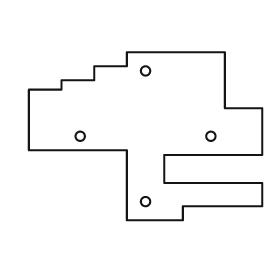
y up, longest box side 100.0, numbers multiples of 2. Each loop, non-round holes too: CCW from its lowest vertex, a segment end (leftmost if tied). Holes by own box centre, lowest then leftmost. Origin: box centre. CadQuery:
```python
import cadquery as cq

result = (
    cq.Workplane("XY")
    .moveTo(-8.0, -36.0)
    .lineTo(16.0, -36.0)
    .lineTo(16.0, -30.0)
    .lineTo(50.0, -30.0)
    .lineTo(50.0, -20.0)
    .lineTo(8.0, -20.0)
    .lineTo(8.0, -8.0)
    .lineTo(50.0, -8.0)
    .lineTo(50.0, 12.0)
    .lineTo(34.0, 12.0)
    .lineTo(34.0, 36.0)
    .lineTo(-8.0, 36.0)
    .lineTo(-8.0, 30.0)
    .lineTo(-22.0, 30.0)
    .lineTo(-22.0, 24.0)
    .lineTo(-36.0, 24.0)
    .lineTo(-36.0, 20.0)
    .lineTo(-50.0, 20.0)
    .lineTo(-50.0, -6.0)
    .lineTo(-8.0, -6.0)
    .close()
    .moveTo(0.0, -28.0)
    .circle(2.0)
    .moveTo(-28.0, 0.0)
    .circle(2.0)
    .moveTo(28.0, 0.0)
    .circle(2.0)
    .moveTo(0.0, 28.0)
    .circle(2.0)
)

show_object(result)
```